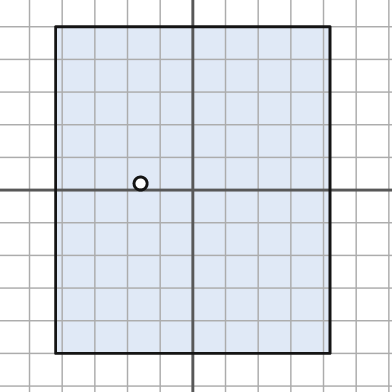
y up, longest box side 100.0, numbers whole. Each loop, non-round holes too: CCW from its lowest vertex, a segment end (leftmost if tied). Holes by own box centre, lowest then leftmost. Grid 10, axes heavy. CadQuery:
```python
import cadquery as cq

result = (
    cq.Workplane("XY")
    .moveTo(-42.0, -50.0)
    .lineTo(42.0, -50.0)
    .lineTo(42.0, 50.0)
    .lineTo(-42.0, 50.0)
    .close()
    .moveTo(-16.0, 2.0)
    .circle(2.0)
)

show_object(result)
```